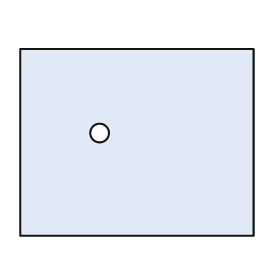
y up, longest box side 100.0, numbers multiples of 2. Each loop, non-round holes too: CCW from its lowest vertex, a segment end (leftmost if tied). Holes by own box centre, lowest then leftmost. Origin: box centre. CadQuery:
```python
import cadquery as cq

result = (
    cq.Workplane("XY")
    .moveTo(-50.0, -40.0)
    .lineTo(50.0, -40.0)
    .lineTo(50.0, 40.0)
    .lineTo(-50.0, 40.0)
    .close()
    .moveTo(-16.0, 4.0)
    .circle(4.0)
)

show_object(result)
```